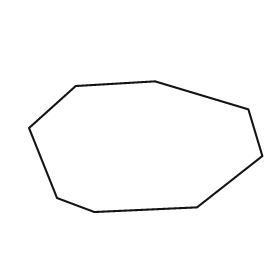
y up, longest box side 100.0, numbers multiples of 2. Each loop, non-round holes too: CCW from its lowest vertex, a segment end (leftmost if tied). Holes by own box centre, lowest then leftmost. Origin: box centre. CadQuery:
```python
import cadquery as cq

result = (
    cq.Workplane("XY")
    .moveTo(-22.0, -28.0)
    .lineTo(22.0, -26.0)
    .lineTo(50.0, -4.0)
    .lineTo(44.0, 16.0)
    .lineTo(4.0, 28.0)
    .lineTo(-30.0, 26.0)
    .lineTo(-50.0, 8.0)
    .lineTo(-38.0, -22.0)
    .close()
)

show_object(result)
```